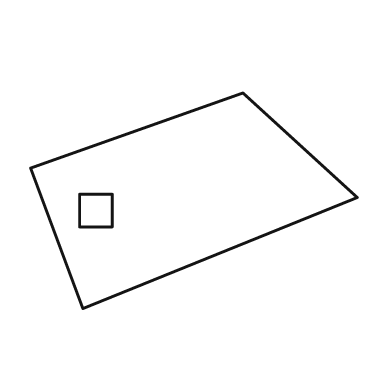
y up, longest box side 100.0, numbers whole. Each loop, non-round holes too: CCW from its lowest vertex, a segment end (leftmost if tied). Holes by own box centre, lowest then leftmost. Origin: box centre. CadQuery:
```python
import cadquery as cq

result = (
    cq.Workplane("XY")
    .moveTo(-34.0, -33.0)
    .lineTo(50.0, 1.0)
    .lineTo(15.0, 33.0)
    .lineTo(-50.0, 10.0)
    .close()
    .moveTo(-35.0, -8.0)
    .lineTo(-25.0, -8.0)
    .lineTo(-25.0, 2.0)
    .lineTo(-35.0, 2.0)
    .close()
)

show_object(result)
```